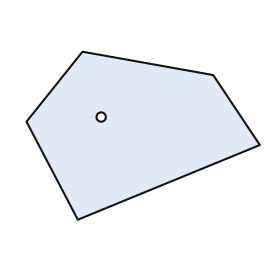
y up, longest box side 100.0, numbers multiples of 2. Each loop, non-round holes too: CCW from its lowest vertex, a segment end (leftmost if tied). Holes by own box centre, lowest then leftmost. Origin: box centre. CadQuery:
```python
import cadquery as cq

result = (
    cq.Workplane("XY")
    .moveTo(-28.0, -36.0)
    .lineTo(50.0, -4.0)
    .lineTo(30.0, 26.0)
    .lineTo(-26.0, 36.0)
    .lineTo(-50.0, 6.0)
    .close()
    .moveTo(-18.0, 8.0)
    .circle(2.0)
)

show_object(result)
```